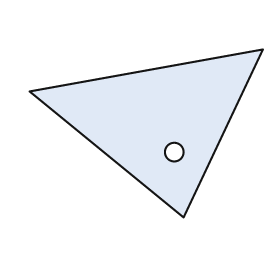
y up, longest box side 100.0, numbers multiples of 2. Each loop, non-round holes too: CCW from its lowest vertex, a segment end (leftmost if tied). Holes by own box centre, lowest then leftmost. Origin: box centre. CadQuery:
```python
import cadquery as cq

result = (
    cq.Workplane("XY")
    .moveTo(16.0, -36.0)
    .lineTo(50.0, 36.0)
    .lineTo(-50.0, 18.0)
    .close()
    .moveTo(12.0, -8.0)
    .circle(4.0)
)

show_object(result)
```